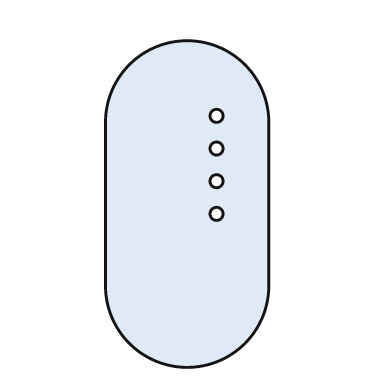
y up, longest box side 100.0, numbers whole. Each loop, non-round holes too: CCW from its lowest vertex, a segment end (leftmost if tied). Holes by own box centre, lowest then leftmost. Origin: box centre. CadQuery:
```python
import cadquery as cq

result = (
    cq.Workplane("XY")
    .moveTo(-25.0, -25.0)
    .threePointArc((0.0, -50.0), (25.0, -25.0))
    .lineTo(25.0, 25.0)
    .threePointArc((0.0, 50.0), (-25.0, 25.0))
    .close()
    .moveTo(9.0, -3.0)
    .circle(2.0)
    .moveTo(9.0, 7.0)
    .circle(2.0)
    .moveTo(9.0, 17.0)
    .circle(2.0)
    .moveTo(9.0, 27.0)
    .circle(2.0)
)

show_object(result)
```